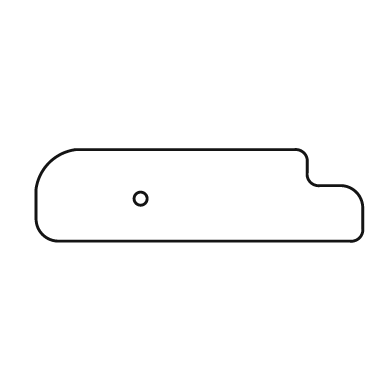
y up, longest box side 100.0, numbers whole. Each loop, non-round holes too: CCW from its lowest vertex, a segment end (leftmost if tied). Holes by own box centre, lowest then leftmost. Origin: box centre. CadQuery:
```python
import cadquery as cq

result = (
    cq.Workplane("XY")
    .moveTo(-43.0, -14.0)
    .lineTo(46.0, -14.0)
    .threePointArc((49.0, -13.0), (50.0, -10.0))
    .lineTo(50.0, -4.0)
    .threePointArc((48.0, 1.0), (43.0, 3.0))
    .lineTo(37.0, 3.0)
    .threePointArc((34.0, 4.0), (33.0, 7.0))
    .lineTo(33.0, 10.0)
    .threePointArc((32.0, 13.0), (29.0, 14.0))
    .lineTo(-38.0, 14.0)
    .threePointArc((-46.0, 10.0), (-50.0, 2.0))
    .lineTo(-50.0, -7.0)
    .threePointArc((-48.0, -12.0), (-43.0, -14.0))
    .close()
    .moveTo(-18.0, -1.0)
    .circle(2.0)
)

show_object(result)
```